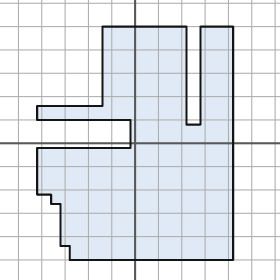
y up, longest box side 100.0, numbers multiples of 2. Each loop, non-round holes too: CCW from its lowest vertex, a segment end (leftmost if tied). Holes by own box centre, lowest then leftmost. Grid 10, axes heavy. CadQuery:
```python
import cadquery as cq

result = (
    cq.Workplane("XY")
    .moveTo(-28.0, -50.0)
    .lineTo(42.0, -50.0)
    .lineTo(42.0, 50.0)
    .lineTo(28.0, 50.0)
    .lineTo(28.0, 8.0)
    .lineTo(22.0, 8.0)
    .lineTo(22.0, 50.0)
    .lineTo(-14.0, 50.0)
    .lineTo(-14.0, 16.0)
    .lineTo(-42.0, 16.0)
    .lineTo(-42.0, 10.0)
    .lineTo(-2.0, 10.0)
    .lineTo(-2.0, -2.0)
    .lineTo(-42.0, -2.0)
    .lineTo(-42.0, -22.0)
    .lineTo(-36.0, -22.0)
    .lineTo(-36.0, -26.0)
    .lineTo(-32.0, -26.0)
    .lineTo(-32.0, -44.0)
    .lineTo(-28.0, -44.0)
    .close()
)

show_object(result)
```